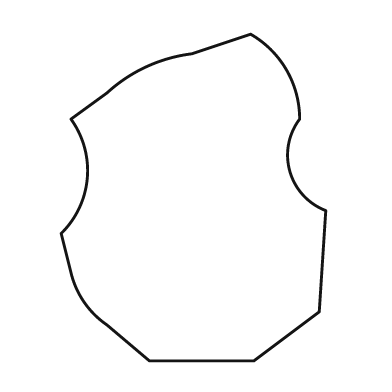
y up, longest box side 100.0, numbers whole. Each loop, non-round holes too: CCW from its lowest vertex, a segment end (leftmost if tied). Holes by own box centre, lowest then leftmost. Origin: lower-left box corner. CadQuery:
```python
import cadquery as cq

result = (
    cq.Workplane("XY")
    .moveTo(27.0, 0.0)
    .lineTo(59.0, 0.0)
    .lineTo(79.0, 15.0)
    .lineTo(81.0, 46.0)
    .threePointArc((70.0, 58.0), (73.0, 74.0))
    .threePointArc((69.0, 89.0), (58.0, 100.0))
    .lineTo(40.0, 94.0)
    .threePointArc((26.0, 90.0), (14.0, 82.0))
    .lineTo(3.0, 74.0)
    .threePointArc((8.0, 56.0), (0.0, 39.0))
    .lineTo(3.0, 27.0)
    .threePointArc((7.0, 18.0), (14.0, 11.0))
    .close()
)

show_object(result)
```